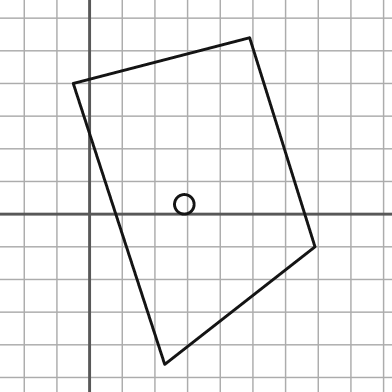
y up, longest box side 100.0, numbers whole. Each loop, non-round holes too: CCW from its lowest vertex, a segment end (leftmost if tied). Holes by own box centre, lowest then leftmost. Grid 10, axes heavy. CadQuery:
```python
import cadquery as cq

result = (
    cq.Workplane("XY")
    .moveTo(23.0, -46.0)
    .lineTo(69.0, -10.0)
    .lineTo(49.0, 54.0)
    .lineTo(-5.0, 40.0)
    .close()
    .moveTo(29.0, 3.0)
    .circle(3.0)
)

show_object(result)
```